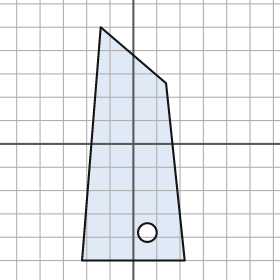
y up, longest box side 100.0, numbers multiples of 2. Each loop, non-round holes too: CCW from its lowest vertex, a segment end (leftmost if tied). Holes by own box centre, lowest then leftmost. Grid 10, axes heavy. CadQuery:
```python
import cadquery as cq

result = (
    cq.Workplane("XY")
    .moveTo(-22.0, -50.0)
    .lineTo(22.0, -50.0)
    .lineTo(14.0, 26.0)
    .lineTo(-14.0, 50.0)
    .close()
    .moveTo(6.0, -38.0)
    .circle(4.0)
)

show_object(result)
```